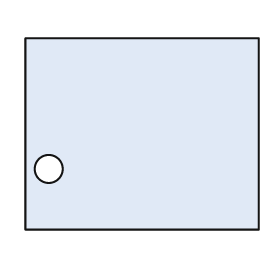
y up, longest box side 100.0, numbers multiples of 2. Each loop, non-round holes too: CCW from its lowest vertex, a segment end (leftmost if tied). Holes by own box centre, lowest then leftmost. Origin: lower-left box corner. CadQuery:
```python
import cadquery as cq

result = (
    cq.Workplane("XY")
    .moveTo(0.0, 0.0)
    .lineTo(100.0, 0.0)
    .lineTo(100.0, 82.0)
    .lineTo(0.0, 82.0)
    .close()
    .moveTo(10.0, 26.0)
    .circle(6.0)
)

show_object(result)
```